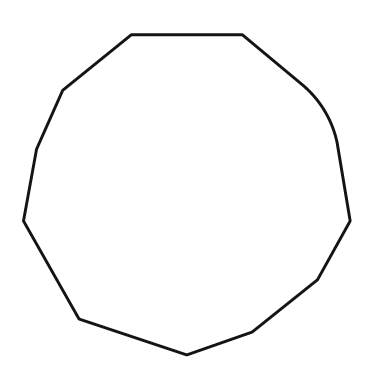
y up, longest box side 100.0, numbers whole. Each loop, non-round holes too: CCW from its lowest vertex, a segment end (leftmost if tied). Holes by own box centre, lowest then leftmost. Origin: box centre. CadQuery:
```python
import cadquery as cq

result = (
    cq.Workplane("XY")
    .moveTo(0.0, -49.0)
    .lineTo(20.0, -42.0)
    .lineTo(40.0, -26.0)
    .lineTo(50.0, -8.0)
    .lineTo(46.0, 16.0)
    .threePointArc((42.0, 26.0), (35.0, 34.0))
    .lineTo(17.0, 49.0)
    .lineTo(-17.0, 49.0)
    .lineTo(-38.0, 32.0)
    .lineTo(-46.0, 14.0)
    .lineTo(-50.0, -8.0)
    .lineTo(-33.0, -38.0)
    .close()
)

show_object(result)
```